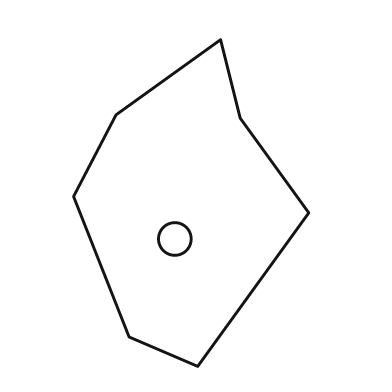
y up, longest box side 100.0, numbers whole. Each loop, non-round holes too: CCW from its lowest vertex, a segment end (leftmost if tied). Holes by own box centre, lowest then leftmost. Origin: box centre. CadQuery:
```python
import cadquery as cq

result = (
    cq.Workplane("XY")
    .moveTo(2.0, -50.0)
    .lineTo(36.0, -3.0)
    .lineTo(15.0, 26.0)
    .lineTo(9.0, 50.0)
    .lineTo(-23.0, 27.0)
    .lineTo(-36.0, 2.0)
    .lineTo(-19.0, -41.0)
    .close()
    .moveTo(-5.0, -11.0)
    .circle(5.0)
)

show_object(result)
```